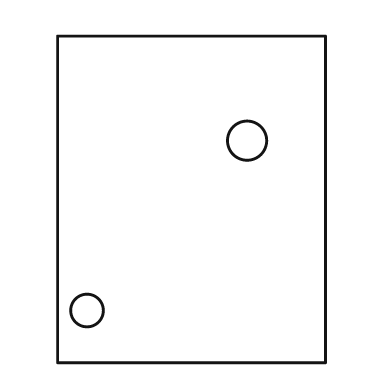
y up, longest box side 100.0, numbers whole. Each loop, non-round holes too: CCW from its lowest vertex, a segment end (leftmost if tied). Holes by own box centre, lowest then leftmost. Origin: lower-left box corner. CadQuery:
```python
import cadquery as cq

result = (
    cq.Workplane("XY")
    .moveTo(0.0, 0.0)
    .lineTo(82.0, 0.0)
    .lineTo(82.0, 100.0)
    .lineTo(0.0, 100.0)
    .close()
    .moveTo(9.0, 16.0)
    .circle(5.0)
    .moveTo(58.0, 68.0)
    .circle(6.0)
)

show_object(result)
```